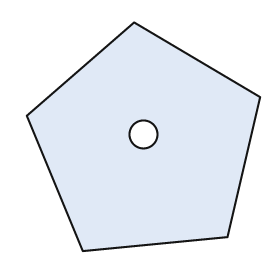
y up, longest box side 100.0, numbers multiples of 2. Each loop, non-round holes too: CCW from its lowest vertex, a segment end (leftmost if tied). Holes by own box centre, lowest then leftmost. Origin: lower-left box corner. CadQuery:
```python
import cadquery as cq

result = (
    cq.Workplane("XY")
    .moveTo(24.0, 0.0)
    .lineTo(86.0, 6.0)
    .lineTo(100.0, 66.0)
    .lineTo(46.0, 98.0)
    .lineTo(0.0, 58.0)
    .close()
    .moveTo(50.0, 50.0)
    .circle(6.0)
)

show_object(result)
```